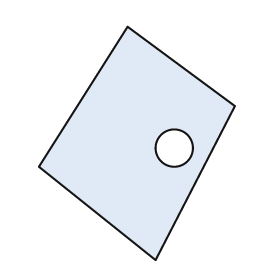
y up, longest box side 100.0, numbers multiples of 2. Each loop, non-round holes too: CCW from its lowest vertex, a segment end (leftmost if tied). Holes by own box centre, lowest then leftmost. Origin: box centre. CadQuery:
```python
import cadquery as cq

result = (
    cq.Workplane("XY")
    .moveTo(8.0, -50.0)
    .lineTo(42.0, 16.0)
    .lineTo(-4.0, 50.0)
    .lineTo(-42.0, -10.0)
    .close()
    .moveTo(16.0, -2.0)
    .circle(8.0)
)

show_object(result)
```